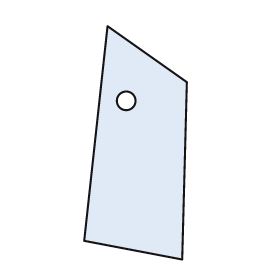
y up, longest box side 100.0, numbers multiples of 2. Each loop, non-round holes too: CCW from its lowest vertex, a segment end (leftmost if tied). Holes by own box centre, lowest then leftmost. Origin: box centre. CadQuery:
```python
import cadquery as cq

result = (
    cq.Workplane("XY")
    .moveTo(20.0, -50.0)
    .lineTo(22.0, 26.0)
    .lineTo(-12.0, 50.0)
    .lineTo(-22.0, -42.0)
    .close()
    .moveTo(-4.0, 18.0)
    .circle(4.0)
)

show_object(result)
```